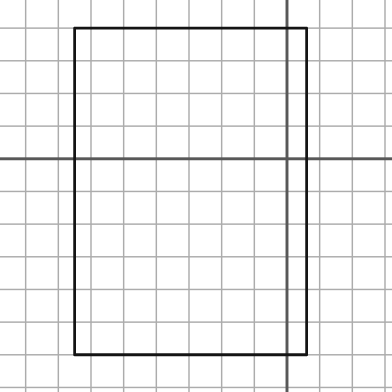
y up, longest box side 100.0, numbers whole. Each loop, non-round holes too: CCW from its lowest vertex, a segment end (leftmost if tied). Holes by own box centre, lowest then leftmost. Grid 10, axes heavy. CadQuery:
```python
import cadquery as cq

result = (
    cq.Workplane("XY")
    .moveTo(-65.0, -60.0)
    .lineTo(6.0, -60.0)
    .lineTo(6.0, 40.0)
    .lineTo(-65.0, 40.0)
    .close()
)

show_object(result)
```